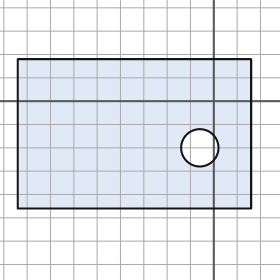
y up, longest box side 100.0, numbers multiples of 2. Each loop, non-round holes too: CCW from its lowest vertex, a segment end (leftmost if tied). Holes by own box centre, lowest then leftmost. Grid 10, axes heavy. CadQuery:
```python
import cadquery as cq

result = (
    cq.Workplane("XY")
    .moveTo(-84.0, -46.0)
    .lineTo(16.0, -46.0)
    .lineTo(16.0, 18.0)
    .lineTo(-84.0, 18.0)
    .close()
    .moveTo(-6.0, -20.0)
    .circle(8.0)
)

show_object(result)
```